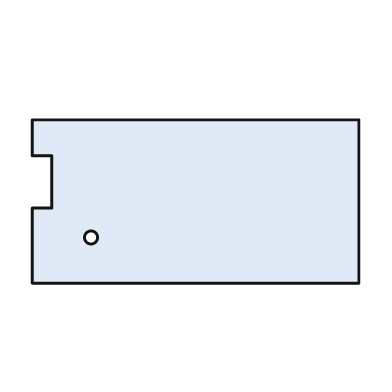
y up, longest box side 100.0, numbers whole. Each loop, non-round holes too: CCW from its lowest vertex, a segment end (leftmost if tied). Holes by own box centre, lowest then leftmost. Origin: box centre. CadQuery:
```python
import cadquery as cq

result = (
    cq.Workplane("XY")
    .moveTo(-50.0, -25.0)
    .lineTo(50.0, -25.0)
    .lineTo(50.0, 25.0)
    .lineTo(-50.0, 25.0)
    .lineTo(-50.0, 14.0)
    .lineTo(-44.0, 14.0)
    .lineTo(-44.0, -2.0)
    .lineTo(-50.0, -2.0)
    .close()
    .moveTo(-32.0, -11.0)
    .circle(2.0)
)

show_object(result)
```